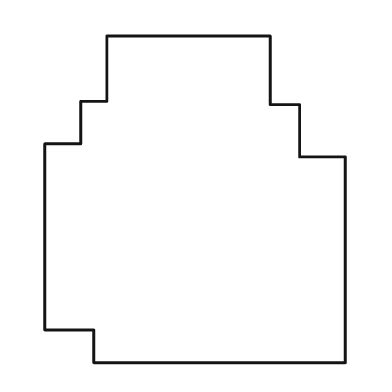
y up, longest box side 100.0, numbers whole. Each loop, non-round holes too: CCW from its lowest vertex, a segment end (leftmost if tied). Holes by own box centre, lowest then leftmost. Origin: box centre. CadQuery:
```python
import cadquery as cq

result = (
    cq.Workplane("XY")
    .moveTo(-31.0, -50.0)
    .lineTo(46.0, -50.0)
    .lineTo(46.0, 13.0)
    .lineTo(32.0, 13.0)
    .lineTo(32.0, 29.0)
    .lineTo(23.0, 29.0)
    .lineTo(23.0, 50.0)
    .lineTo(-27.0, 50.0)
    .lineTo(-27.0, 30.0)
    .lineTo(-35.0, 30.0)
    .lineTo(-35.0, 17.0)
    .lineTo(-46.0, 17.0)
    .lineTo(-46.0, -40.0)
    .lineTo(-31.0, -40.0)
    .close()
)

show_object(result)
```